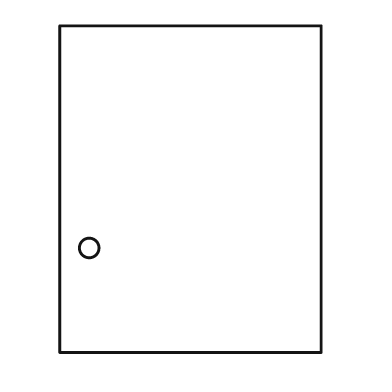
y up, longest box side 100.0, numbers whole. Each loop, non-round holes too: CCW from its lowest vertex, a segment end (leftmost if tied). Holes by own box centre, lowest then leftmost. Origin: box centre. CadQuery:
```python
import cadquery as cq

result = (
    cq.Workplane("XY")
    .moveTo(-40.0, -50.0)
    .lineTo(40.0, -50.0)
    .lineTo(40.0, 50.0)
    .lineTo(-40.0, 50.0)
    .close()
    .moveTo(-31.0, -18.0)
    .circle(3.0)
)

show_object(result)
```